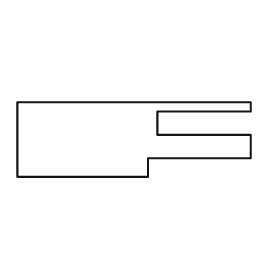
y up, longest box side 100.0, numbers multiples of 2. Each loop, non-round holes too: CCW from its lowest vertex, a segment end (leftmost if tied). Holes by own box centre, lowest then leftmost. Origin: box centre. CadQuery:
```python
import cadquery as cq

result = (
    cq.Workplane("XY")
    .moveTo(-50.0, -16.0)
    .lineTo(6.0, -16.0)
    .lineTo(6.0, -8.0)
    .lineTo(50.0, -8.0)
    .lineTo(50.0, 2.0)
    .lineTo(10.0, 2.0)
    .lineTo(10.0, 12.0)
    .lineTo(50.0, 12.0)
    .lineTo(50.0, 16.0)
    .lineTo(-50.0, 16.0)
    .close()
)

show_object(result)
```